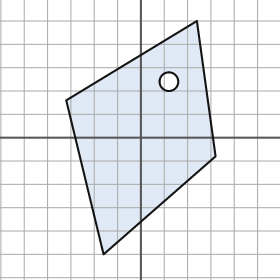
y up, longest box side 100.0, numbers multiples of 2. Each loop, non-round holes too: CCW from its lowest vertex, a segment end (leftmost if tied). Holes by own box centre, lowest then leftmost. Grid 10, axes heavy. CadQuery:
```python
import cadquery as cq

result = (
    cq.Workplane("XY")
    .moveTo(-16.0, -50.0)
    .lineTo(32.0, -8.0)
    .lineTo(24.0, 50.0)
    .lineTo(-32.0, 16.0)
    .close()
    .moveTo(12.0, 24.0)
    .circle(4.0)
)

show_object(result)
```